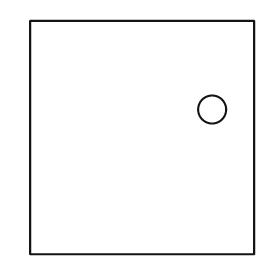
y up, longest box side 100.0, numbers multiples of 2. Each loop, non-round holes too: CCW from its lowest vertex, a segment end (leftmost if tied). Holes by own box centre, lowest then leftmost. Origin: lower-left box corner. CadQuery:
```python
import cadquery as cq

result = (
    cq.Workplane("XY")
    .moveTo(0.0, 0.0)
    .lineTo(96.0, 0.0)
    .lineTo(96.0, 100.0)
    .lineTo(0.0, 100.0)
    .close()
    .moveTo(78.0, 62.0)
    .circle(6.0)
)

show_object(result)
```